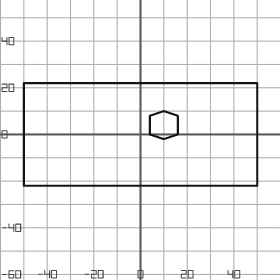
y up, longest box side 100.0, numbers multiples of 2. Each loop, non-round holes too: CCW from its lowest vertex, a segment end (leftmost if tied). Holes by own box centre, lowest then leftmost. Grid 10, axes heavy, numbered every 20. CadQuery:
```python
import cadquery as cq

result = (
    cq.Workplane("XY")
    .moveTo(-50.0, -22.0)
    .lineTo(50.0, -22.0)
    .lineTo(50.0, 22.0)
    .lineTo(-50.0, 22.0)
    .close()
    .moveTo(10.0, -2.0)
    .lineTo(16.0, 0.0)
    .lineTo(16.0, 8.0)
    .lineTo(10.0, 10.0)
    .lineTo(4.0, 8.0)
    .lineTo(4.0, 0.0)
    .close()
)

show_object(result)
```